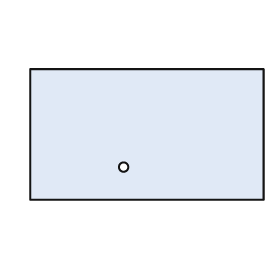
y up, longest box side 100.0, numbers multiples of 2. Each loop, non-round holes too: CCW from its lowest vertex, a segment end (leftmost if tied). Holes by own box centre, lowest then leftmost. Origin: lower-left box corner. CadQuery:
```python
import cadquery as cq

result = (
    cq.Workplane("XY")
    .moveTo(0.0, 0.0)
    .lineTo(100.0, 0.0)
    .lineTo(100.0, 56.0)
    .lineTo(0.0, 56.0)
    .close()
    .moveTo(40.0, 14.0)
    .circle(2.0)
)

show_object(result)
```